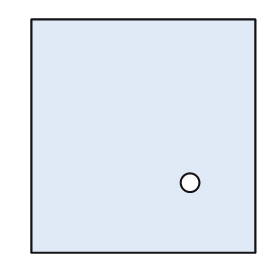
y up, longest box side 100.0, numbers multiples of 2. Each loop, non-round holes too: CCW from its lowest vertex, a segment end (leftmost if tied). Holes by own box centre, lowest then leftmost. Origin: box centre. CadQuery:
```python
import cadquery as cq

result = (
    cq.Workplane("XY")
    .moveTo(-48.0, -50.0)
    .lineTo(48.0, -50.0)
    .lineTo(48.0, 50.0)
    .lineTo(-48.0, 50.0)
    .close()
    .moveTo(20.0, -20.0)
    .circle(4.0)
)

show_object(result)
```